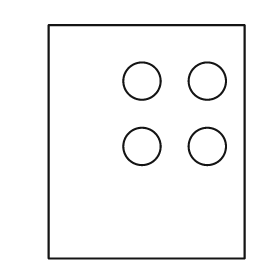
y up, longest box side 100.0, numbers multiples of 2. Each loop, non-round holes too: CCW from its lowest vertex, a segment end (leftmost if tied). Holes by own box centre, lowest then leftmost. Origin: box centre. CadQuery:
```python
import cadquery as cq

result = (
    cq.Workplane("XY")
    .moveTo(-42.0, -50.0)
    .lineTo(42.0, -50.0)
    .lineTo(42.0, 50.0)
    .lineTo(-42.0, 50.0)
    .close()
    .moveTo(-2.0, -2.0)
    .circle(8.0)
    .moveTo(26.0, -2.0)
    .circle(8.0)
    .moveTo(-2.0, 26.0)
    .circle(8.0)
    .moveTo(26.0, 26.0)
    .circle(8.0)
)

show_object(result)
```